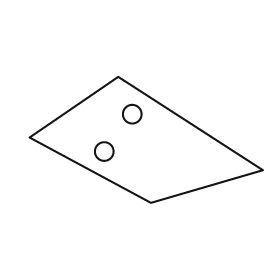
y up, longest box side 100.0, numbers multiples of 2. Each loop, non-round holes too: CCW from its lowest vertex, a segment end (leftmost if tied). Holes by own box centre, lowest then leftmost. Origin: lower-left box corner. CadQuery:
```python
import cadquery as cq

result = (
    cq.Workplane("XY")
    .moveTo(52.0, 0.0)
    .lineTo(100.0, 14.0)
    .lineTo(38.0, 54.0)
    .lineTo(0.0, 28.0)
    .close()
    .moveTo(32.0, 22.0)
    .circle(4.0)
    .moveTo(44.0, 38.0)
    .circle(4.0)
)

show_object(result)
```